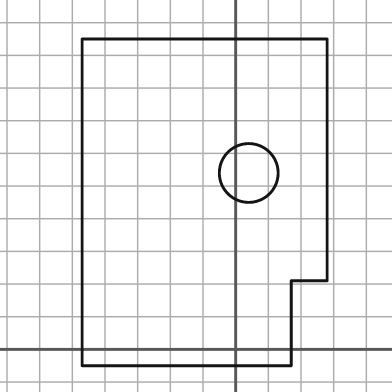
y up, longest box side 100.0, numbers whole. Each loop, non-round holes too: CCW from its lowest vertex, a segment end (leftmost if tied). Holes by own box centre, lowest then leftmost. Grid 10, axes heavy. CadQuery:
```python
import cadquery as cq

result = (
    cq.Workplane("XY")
    .moveTo(-47.0, -5.0)
    .lineTo(17.0, -5.0)
    .lineTo(17.0, 21.0)
    .lineTo(28.0, 21.0)
    .lineTo(28.0, 95.0)
    .lineTo(-47.0, 95.0)
    .close()
    .moveTo(4.0, 54.0)
    .circle(9.0)
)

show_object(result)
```